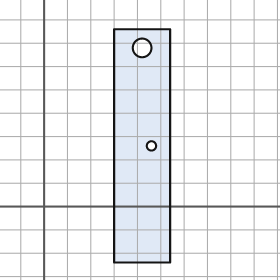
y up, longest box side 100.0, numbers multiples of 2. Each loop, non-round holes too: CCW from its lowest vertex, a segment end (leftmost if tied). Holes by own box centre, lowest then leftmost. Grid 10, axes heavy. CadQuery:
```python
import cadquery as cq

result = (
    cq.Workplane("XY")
    .moveTo(30.0, -24.0)
    .lineTo(54.0, -24.0)
    .lineTo(54.0, 76.0)
    .lineTo(30.0, 76.0)
    .close()
    .moveTo(46.0, 26.0)
    .circle(2.0)
    .moveTo(42.0, 68.0)
    .circle(4.0)
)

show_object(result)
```